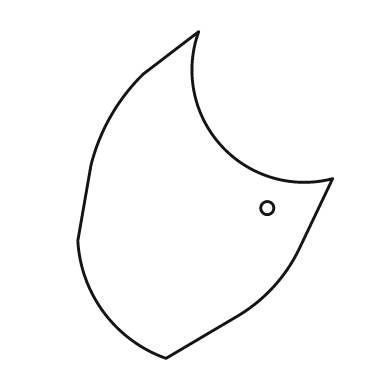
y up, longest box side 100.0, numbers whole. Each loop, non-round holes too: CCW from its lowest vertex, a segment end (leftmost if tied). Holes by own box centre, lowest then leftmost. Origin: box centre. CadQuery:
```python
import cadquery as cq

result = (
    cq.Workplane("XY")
    .moveTo(-12.0, -50.0)
    .lineTo(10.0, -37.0)
    .threePointArc((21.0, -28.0), (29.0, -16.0))
    .lineTo(39.0, 5.0)
    .threePointArc((5.0, 15.0), (-2.0, 50.0))
    .lineTo(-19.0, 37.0)
    .threePointArc((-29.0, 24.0), (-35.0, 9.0))
    .lineTo(-39.0, -14.0)
    .threePointArc((-31.0, -36.0), (-12.0, -50.0))
    .close()
    .moveTo(19.0, -4.0)
    .circle(2.0)
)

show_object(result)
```